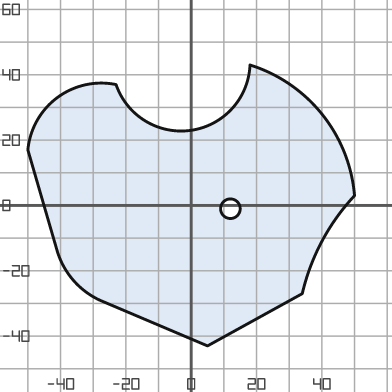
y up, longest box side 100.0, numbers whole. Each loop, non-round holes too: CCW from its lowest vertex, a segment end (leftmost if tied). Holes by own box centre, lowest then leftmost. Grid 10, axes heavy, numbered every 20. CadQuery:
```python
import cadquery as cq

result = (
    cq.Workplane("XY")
    .moveTo(5.0, -43.0)
    .lineTo(34.0, -27.0)
    .threePointArc((40.0, -11.0), (50.0, 3.0))
    .threePointArc((40.0, 28.0), (18.0, 43.0))
    .threePointArc((0.0, 23.0), (-23.0, 37.0))
    .threePointArc((-41.0, 33.0), (-50.0, 17.0))
    .lineTo(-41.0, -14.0)
    .threePointArc((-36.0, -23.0), (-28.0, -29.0))
    .close()
    .moveTo(12.0, -1.0)
    .circle(3.0)
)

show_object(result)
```